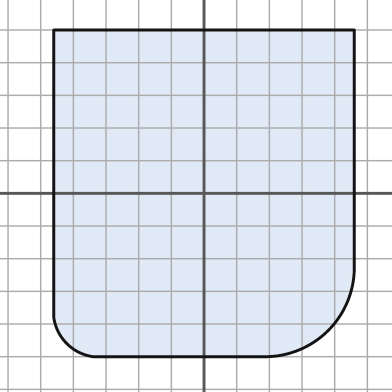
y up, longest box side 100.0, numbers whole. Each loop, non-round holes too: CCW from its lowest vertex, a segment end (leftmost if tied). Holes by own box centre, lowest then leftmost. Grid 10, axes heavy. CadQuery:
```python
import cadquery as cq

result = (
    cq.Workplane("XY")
    .moveTo(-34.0, -50.0)
    .lineTo(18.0, -50.0)
    .threePointArc((38.0, -42.0), (46.0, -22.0))
    .lineTo(46.0, 50.0)
    .lineTo(-46.0, 50.0)
    .lineTo(-46.0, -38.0)
    .threePointArc((-42.0, -46.0), (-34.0, -50.0))
    .close()
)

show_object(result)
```